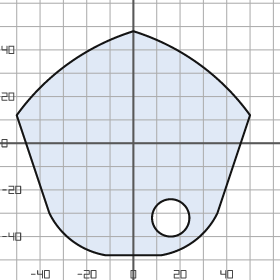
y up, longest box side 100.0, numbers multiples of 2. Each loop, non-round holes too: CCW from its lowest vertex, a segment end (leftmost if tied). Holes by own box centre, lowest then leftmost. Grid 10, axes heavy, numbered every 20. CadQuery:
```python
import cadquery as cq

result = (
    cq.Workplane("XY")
    .moveTo(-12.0, -48.0)
    .lineTo(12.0, -48.0)
    .threePointArc((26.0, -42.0), (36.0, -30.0))
    .lineTo(50.0, 12.0)
    .threePointArc((28.0, 34.0), (0.0, 48.0))
    .threePointArc((-28.0, 34.0), (-50.0, 12.0))
    .lineTo(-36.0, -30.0)
    .threePointArc((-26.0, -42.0), (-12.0, -48.0))
    .close()
    .moveTo(16.0, -32.0)
    .circle(8.0)
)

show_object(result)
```